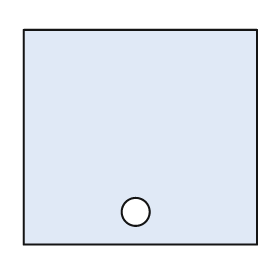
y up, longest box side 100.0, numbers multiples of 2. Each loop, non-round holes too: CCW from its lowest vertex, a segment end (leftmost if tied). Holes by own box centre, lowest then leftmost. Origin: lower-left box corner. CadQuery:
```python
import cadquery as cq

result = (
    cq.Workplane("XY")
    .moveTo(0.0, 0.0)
    .lineTo(100.0, 0.0)
    .lineTo(100.0, 92.0)
    .lineTo(0.0, 92.0)
    .close()
    .moveTo(48.0, 14.0)
    .circle(6.0)
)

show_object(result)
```